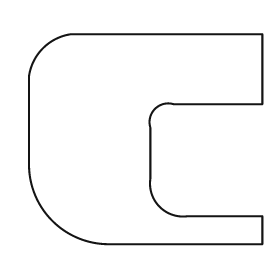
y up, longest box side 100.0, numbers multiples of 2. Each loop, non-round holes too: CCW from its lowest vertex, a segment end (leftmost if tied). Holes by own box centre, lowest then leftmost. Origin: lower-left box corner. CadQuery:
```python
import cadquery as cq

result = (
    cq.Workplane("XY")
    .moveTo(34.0, 0.0)
    .lineTo(100.0, 0.0)
    .lineTo(100.0, 12.0)
    .lineTo(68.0, 12.0)
    .threePointArc((56.0, 16.0), (52.0, 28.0))
    .lineTo(52.0, 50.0)
    .threePointArc((54.0, 58.0), (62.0, 60.0))
    .lineTo(100.0, 60.0)
    .lineTo(100.0, 90.0)
    .lineTo(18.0, 90.0)
    .threePointArc((6.0, 84.0), (0.0, 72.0))
    .lineTo(0.0, 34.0)
    .threePointArc((10.0, 10.0), (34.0, 0.0))
    .close()
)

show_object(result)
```